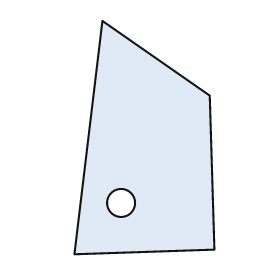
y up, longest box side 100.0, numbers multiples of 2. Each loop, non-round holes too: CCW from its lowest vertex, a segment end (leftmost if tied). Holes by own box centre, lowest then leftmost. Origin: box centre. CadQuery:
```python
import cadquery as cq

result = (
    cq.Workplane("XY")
    .moveTo(-30.0, -50.0)
    .lineTo(30.0, -48.0)
    .lineTo(28.0, 18.0)
    .lineTo(-18.0, 50.0)
    .close()
    .moveTo(-10.0, -28.0)
    .circle(6.0)
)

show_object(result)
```